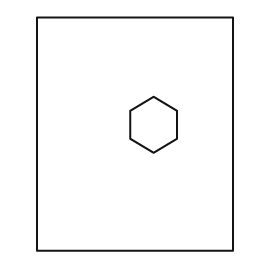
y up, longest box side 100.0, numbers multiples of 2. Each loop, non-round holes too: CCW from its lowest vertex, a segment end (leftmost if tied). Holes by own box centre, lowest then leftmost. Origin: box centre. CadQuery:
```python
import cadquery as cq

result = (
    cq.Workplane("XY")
    .moveTo(-42.0, -50.0)
    .lineTo(42.0, -50.0)
    .lineTo(42.0, 50.0)
    .lineTo(-42.0, 50.0)
    .close()
    .moveTo(8.0, -8.0)
    .lineTo(18.0, -2.0)
    .lineTo(18.0, 10.0)
    .lineTo(8.0, 16.0)
    .lineTo(-2.0, 10.0)
    .lineTo(-2.0, -2.0)
    .close()
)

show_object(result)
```